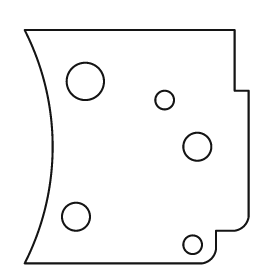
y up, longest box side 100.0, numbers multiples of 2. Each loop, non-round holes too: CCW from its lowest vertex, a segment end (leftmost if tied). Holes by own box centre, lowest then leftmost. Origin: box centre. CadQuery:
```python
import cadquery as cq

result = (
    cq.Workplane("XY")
    .moveTo(-48.0, -50.0)
    .lineTo(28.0, -50.0)
    .threePointArc((32.0, -48.0), (34.0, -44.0))
    .lineTo(34.0, -36.0)
    .lineTo(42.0, -36.0)
    .threePointArc((46.0, -34.0), (48.0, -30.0))
    .lineTo(48.0, 24.0)
    .lineTo(42.0, 24.0)
    .lineTo(42.0, 50.0)
    .lineTo(-48.0, 50.0)
    .threePointArc((-36.0, 0.0), (-48.0, -50.0))
    .close()
    .moveTo(24.0, -42.0)
    .circle(4.0)
    .moveTo(-26.0, -30.0)
    .circle(6.0)
    .moveTo(26.0, 0.0)
    .circle(6.0)
    .moveTo(12.0, 20.0)
    .circle(4.0)
    .moveTo(-22.0, 28.0)
    .circle(8.0)
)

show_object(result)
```